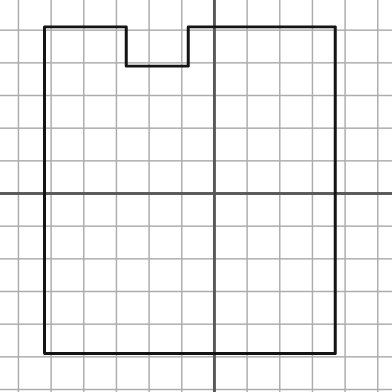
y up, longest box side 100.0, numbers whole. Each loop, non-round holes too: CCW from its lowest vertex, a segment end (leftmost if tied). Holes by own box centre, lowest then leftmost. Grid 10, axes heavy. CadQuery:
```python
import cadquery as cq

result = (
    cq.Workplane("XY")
    .moveTo(-52.0, -49.0)
    .lineTo(37.0, -49.0)
    .lineTo(37.0, 51.0)
    .lineTo(-8.0, 51.0)
    .lineTo(-8.0, 39.0)
    .lineTo(-27.0, 39.0)
    .lineTo(-27.0, 51.0)
    .lineTo(-52.0, 51.0)
    .close()
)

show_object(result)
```